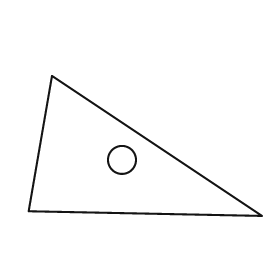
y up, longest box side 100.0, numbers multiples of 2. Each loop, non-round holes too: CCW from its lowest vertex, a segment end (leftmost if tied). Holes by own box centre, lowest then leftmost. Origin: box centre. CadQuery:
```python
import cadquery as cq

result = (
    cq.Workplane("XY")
    .moveTo(50.0, -30.0)
    .lineTo(-40.0, 30.0)
    .lineTo(-50.0, -28.0)
    .close()
    .moveTo(-10.0, -6.0)
    .circle(6.0)
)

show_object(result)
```